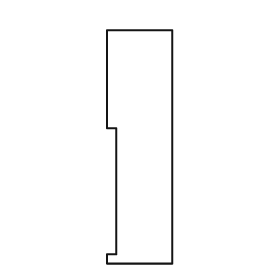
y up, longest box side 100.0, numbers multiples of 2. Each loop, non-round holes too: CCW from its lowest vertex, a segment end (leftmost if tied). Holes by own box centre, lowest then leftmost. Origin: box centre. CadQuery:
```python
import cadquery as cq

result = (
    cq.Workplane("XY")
    .moveTo(-14.0, -50.0)
    .lineTo(14.0, -50.0)
    .lineTo(14.0, 50.0)
    .lineTo(-14.0, 50.0)
    .lineTo(-14.0, 8.0)
    .lineTo(-10.0, 8.0)
    .lineTo(-10.0, -46.0)
    .lineTo(-14.0, -46.0)
    .close()
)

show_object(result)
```